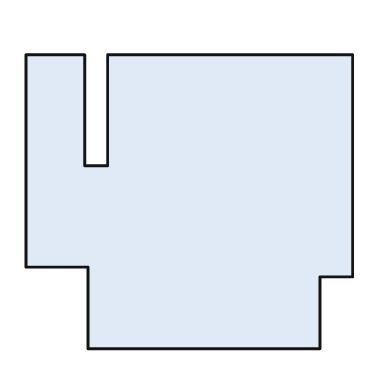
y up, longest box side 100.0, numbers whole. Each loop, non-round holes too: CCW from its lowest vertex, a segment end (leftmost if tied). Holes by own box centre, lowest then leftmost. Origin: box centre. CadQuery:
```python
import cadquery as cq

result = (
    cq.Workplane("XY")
    .moveTo(-31.0, -45.0)
    .lineTo(40.0, -45.0)
    .lineTo(40.0, -23.0)
    .lineTo(50.0, -23.0)
    .lineTo(50.0, 45.0)
    .lineTo(-25.0, 45.0)
    .lineTo(-25.0, 11.0)
    .lineTo(-32.0, 11.0)
    .lineTo(-32.0, 45.0)
    .lineTo(-50.0, 45.0)
    .lineTo(-50.0, -20.0)
    .lineTo(-31.0, -20.0)
    .close()
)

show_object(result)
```